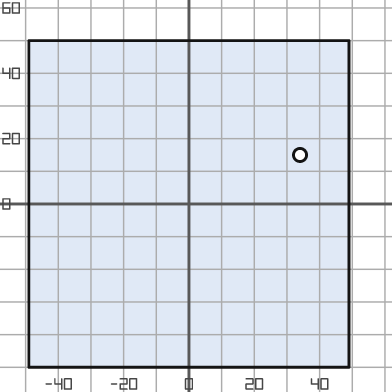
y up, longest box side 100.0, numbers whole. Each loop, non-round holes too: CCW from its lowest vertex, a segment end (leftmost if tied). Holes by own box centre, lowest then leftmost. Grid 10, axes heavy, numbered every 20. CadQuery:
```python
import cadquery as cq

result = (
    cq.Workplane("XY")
    .moveTo(-49.0, -50.0)
    .lineTo(49.0, -50.0)
    .lineTo(49.0, 50.0)
    .lineTo(-49.0, 50.0)
    .close()
    .moveTo(34.0, 15.0)
    .circle(2.0)
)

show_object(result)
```